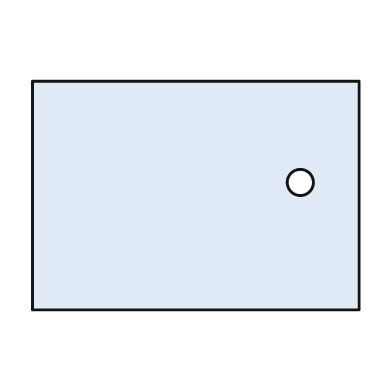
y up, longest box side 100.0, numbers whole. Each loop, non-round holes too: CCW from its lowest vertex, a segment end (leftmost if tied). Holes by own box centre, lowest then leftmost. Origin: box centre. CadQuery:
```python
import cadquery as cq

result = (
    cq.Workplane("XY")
    .moveTo(-50.0, -35.0)
    .lineTo(50.0, -35.0)
    .lineTo(50.0, 35.0)
    .lineTo(-50.0, 35.0)
    .close()
    .moveTo(32.0, 4.0)
    .circle(4.0)
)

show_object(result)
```